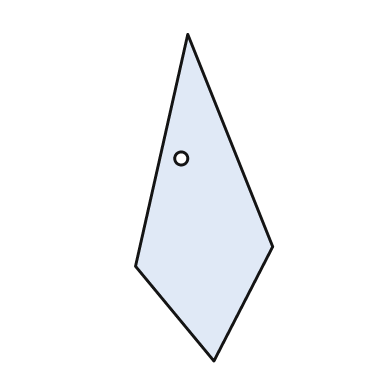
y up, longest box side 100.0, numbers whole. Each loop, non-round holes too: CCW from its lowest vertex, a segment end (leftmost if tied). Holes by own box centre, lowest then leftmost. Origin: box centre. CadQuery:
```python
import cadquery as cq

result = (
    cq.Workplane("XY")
    .moveTo(3.0, -50.0)
    .lineTo(21.0, -15.0)
    .lineTo(-5.0, 50.0)
    .lineTo(-21.0, -21.0)
    .close()
    .moveTo(-7.0, 12.0)
    .circle(2.0)
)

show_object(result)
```